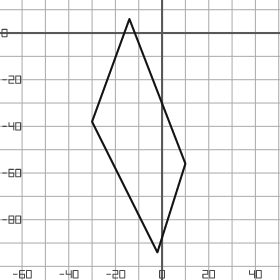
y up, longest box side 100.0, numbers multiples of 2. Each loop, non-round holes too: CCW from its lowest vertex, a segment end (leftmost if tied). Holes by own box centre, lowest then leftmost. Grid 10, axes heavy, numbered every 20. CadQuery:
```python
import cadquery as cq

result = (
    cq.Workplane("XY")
    .moveTo(-2.0, -94.0)
    .lineTo(10.0, -56.0)
    .lineTo(-14.0, 6.0)
    .lineTo(-30.0, -38.0)
    .close()
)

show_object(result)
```